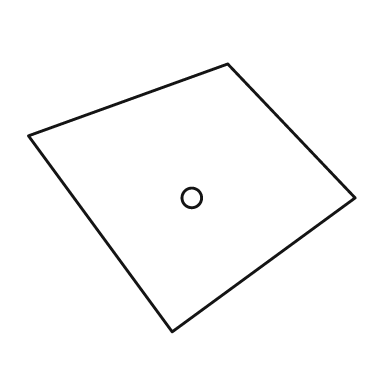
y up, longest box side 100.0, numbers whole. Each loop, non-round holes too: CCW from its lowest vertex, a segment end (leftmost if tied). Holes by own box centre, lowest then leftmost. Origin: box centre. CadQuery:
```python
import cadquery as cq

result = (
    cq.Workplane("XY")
    .moveTo(-6.0, -41.0)
    .lineTo(50.0, 0.0)
    .lineTo(11.0, 41.0)
    .lineTo(-50.0, 19.0)
    .close()
    .moveTo(0.0, 0.0)
    .circle(3.0)
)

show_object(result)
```